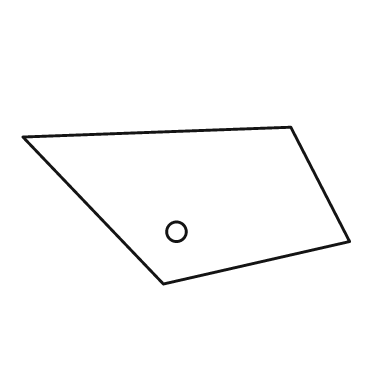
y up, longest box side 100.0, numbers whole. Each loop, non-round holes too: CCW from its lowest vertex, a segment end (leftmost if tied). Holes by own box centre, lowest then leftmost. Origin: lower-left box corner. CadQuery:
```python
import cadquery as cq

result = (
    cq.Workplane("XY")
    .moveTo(43.0, 0.0)
    .lineTo(100.0, 13.0)
    .lineTo(82.0, 48.0)
    .lineTo(0.0, 45.0)
    .close()
    .moveTo(47.0, 16.0)
    .circle(3.0)
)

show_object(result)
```